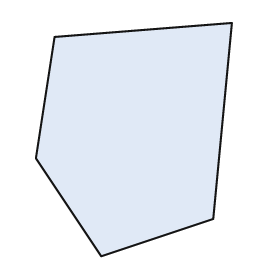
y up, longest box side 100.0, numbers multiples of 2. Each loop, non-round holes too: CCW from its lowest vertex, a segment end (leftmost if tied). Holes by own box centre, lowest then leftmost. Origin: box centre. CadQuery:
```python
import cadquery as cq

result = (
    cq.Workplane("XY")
    .moveTo(-14.0, -50.0)
    .lineTo(34.0, -34.0)
    .lineTo(42.0, 50.0)
    .lineTo(-34.0, 44.0)
    .lineTo(-42.0, -8.0)
    .close()
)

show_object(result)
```